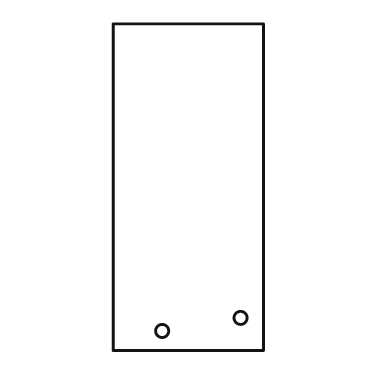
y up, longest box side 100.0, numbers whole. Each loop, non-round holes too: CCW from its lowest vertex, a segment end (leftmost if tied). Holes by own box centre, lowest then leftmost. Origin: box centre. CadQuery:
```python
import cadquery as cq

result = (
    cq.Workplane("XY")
    .moveTo(-23.0, -50.0)
    .lineTo(23.0, -50.0)
    .lineTo(23.0, 50.0)
    .lineTo(-23.0, 50.0)
    .close()
    .moveTo(-8.0, -44.0)
    .circle(2.0)
    .moveTo(16.0, -40.0)
    .circle(2.0)
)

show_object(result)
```